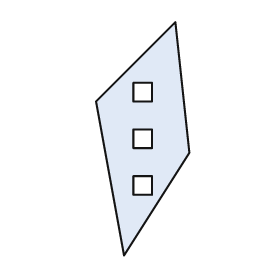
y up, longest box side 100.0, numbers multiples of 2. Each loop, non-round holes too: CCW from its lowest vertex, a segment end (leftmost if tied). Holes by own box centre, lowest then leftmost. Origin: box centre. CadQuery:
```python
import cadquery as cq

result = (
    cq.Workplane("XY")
    .moveTo(-8.0, -50.0)
    .lineTo(20.0, -6.0)
    .lineTo(14.0, 50.0)
    .lineTo(-20.0, 16.0)
    .close()
    .moveTo(-4.0, -24.0)
    .lineTo(4.0, -24.0)
    .lineTo(4.0, -16.0)
    .lineTo(-4.0, -16.0)
    .close()
    .moveTo(-4.0, -4.0)
    .lineTo(4.0, -4.0)
    .lineTo(4.0, 4.0)
    .lineTo(-4.0, 4.0)
    .close()
    .moveTo(-4.0, 16.0)
    .lineTo(4.0, 16.0)
    .lineTo(4.0, 24.0)
    .lineTo(-4.0, 24.0)
    .close()
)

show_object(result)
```